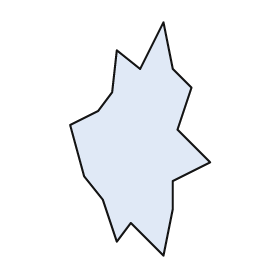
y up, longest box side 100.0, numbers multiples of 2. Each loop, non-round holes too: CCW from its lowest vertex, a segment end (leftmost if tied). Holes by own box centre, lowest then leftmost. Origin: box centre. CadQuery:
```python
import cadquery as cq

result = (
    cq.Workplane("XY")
    .moveTo(10.0, -50.0)
    .lineTo(14.0, -30.0)
    .lineTo(14.0, -18.0)
    .lineTo(30.0, -10.0)
    .lineTo(16.0, 4.0)
    .lineTo(22.0, 22.0)
    .lineTo(14.0, 30.0)
    .lineTo(10.0, 50.0)
    .lineTo(0.0, 30.0)
    .lineTo(-10.0, 38.0)
    .lineTo(-12.0, 20.0)
    .lineTo(-18.0, 12.0)
    .lineTo(-30.0, 6.0)
    .lineTo(-24.0, -16.0)
    .lineTo(-16.0, -26.0)
    .lineTo(-10.0, -44.0)
    .lineTo(-4.0, -36.0)
    .close()
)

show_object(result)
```